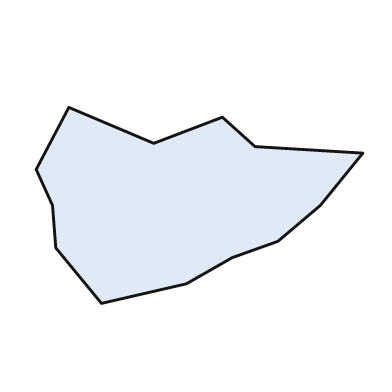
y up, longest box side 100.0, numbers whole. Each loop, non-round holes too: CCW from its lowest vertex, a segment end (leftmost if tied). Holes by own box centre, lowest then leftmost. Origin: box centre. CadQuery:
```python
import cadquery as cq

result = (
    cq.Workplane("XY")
    .moveTo(-30.0, -30.0)
    .lineTo(-4.0, -24.0)
    .lineTo(10.0, -16.0)
    .lineTo(24.0, -11.0)
    .lineTo(37.0, 0.0)
    .lineTo(50.0, 16.0)
    .lineTo(17.0, 18.0)
    .lineTo(7.0, 27.0)
    .lineTo(-14.0, 19.0)
    .lineTo(-40.0, 30.0)
    .lineTo(-50.0, 11.0)
    .lineTo(-45.0, 0.0)
    .lineTo(-44.0, -13.0)
    .close()
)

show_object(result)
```